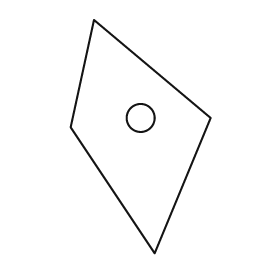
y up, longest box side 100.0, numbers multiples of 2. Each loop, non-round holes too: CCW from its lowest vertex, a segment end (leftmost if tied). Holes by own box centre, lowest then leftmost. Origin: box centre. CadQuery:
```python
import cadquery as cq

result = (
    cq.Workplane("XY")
    .moveTo(6.0, -50.0)
    .lineTo(30.0, 8.0)
    .lineTo(-20.0, 50.0)
    .lineTo(-30.0, 4.0)
    .close()
    .moveTo(0.0, 8.0)
    .circle(6.0)
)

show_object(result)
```